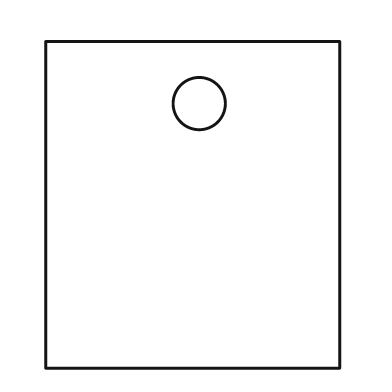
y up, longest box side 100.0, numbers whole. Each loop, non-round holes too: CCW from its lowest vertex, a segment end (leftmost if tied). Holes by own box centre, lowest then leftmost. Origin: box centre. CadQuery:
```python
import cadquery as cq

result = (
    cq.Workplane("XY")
    .moveTo(-45.0, -50.0)
    .lineTo(45.0, -50.0)
    .lineTo(45.0, 50.0)
    .lineTo(-45.0, 50.0)
    .close()
    .moveTo(2.0, 31.0)
    .circle(8.0)
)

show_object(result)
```